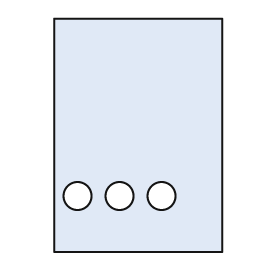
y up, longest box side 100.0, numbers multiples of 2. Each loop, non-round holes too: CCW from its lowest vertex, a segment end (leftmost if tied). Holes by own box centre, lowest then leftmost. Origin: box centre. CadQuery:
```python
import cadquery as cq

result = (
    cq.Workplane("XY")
    .moveTo(-36.0, -50.0)
    .lineTo(36.0, -50.0)
    .lineTo(36.0, 50.0)
    .lineTo(-36.0, 50.0)
    .close()
    .moveTo(-26.0, -26.0)
    .circle(6.0)
    .moveTo(-8.0, -26.0)
    .circle(6.0)
    .moveTo(10.0, -26.0)
    .circle(6.0)
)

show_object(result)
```